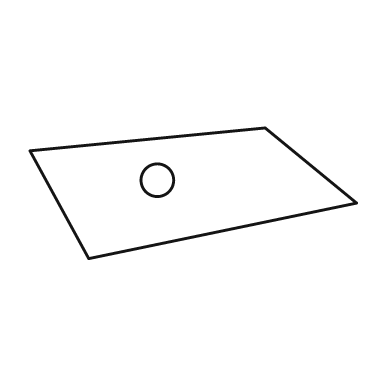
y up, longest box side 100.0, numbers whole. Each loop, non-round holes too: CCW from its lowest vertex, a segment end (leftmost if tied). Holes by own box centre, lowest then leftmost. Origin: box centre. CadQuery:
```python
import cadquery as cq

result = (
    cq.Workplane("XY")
    .moveTo(-32.0, -20.0)
    .lineTo(50.0, -3.0)
    .lineTo(22.0, 20.0)
    .lineTo(-50.0, 13.0)
    .close()
    .moveTo(-11.0, 4.0)
    .circle(5.0)
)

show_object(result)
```